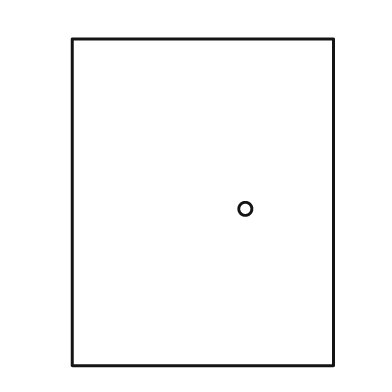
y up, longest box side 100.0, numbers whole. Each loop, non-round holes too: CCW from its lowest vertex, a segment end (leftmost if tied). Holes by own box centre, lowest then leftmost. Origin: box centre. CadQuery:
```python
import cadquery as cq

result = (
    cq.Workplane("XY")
    .moveTo(-40.0, -50.0)
    .lineTo(40.0, -50.0)
    .lineTo(40.0, 50.0)
    .lineTo(-40.0, 50.0)
    .close()
    .moveTo(13.0, -2.0)
    .circle(2.0)
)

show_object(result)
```